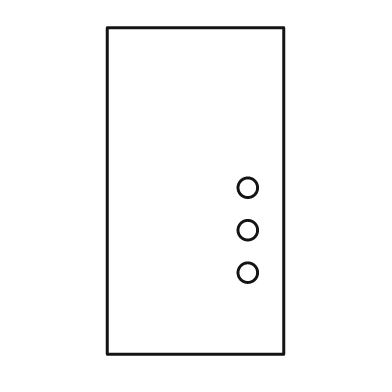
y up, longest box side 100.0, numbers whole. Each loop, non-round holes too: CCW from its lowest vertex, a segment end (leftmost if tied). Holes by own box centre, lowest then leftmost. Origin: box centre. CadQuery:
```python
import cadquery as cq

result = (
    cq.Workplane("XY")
    .moveTo(-27.0, -50.0)
    .lineTo(27.0, -50.0)
    .lineTo(27.0, 50.0)
    .lineTo(-27.0, 50.0)
    .close()
    .moveTo(16.0, -25.0)
    .circle(3.0)
    .moveTo(16.0, -12.0)
    .circle(3.0)
    .moveTo(16.0, 1.0)
    .circle(3.0)
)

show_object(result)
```